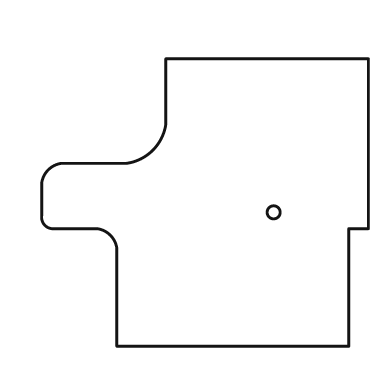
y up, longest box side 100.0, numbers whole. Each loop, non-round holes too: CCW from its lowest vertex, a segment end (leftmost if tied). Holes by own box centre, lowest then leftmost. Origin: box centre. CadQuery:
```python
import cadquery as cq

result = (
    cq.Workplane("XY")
    .moveTo(-27.0, -44.0)
    .lineTo(44.0, -44.0)
    .lineTo(44.0, -8.0)
    .lineTo(50.0, -8.0)
    .lineTo(50.0, 44.0)
    .lineTo(-12.0, 44.0)
    .lineTo(-12.0, 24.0)
    .threePointArc((-16.0, 16.0), (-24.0, 12.0))
    .lineTo(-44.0, 12.0)
    .threePointArc((-48.0, 10.0), (-50.0, 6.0))
    .lineTo(-50.0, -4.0)
    .threePointArc((-49.0, -7.0), (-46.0, -8.0))
    .lineTo(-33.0, -8.0)
    .threePointArc((-29.0, -10.0), (-27.0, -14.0))
    .close()
    .moveTo(21.0, -3.0)
    .circle(2.0)
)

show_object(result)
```